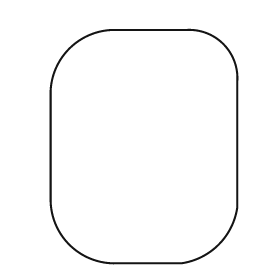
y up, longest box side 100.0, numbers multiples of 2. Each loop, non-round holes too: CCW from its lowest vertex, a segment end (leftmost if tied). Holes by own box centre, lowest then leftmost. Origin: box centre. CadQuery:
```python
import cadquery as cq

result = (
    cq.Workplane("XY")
    .moveTo(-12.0, -50.0)
    .lineTo(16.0, -50.0)
    .threePointArc((32.0, -42.0), (40.0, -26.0))
    .lineTo(40.0, 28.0)
    .threePointArc((34.0, 44.0), (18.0, 50.0))
    .lineTo(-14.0, 50.0)
    .threePointArc((-32.0, 42.0), (-40.0, 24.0))
    .lineTo(-40.0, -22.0)
    .threePointArc((-32.0, -42.0), (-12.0, -50.0))
    .close()
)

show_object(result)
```